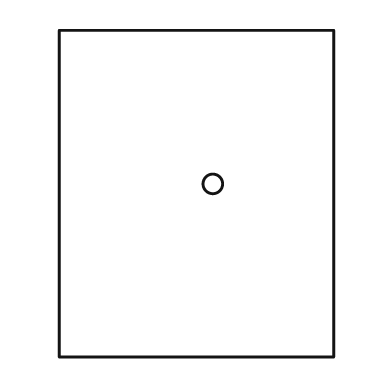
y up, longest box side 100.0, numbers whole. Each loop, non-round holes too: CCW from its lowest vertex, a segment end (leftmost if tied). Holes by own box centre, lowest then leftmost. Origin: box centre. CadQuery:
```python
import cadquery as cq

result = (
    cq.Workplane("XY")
    .moveTo(-42.0, -50.0)
    .lineTo(42.0, -50.0)
    .lineTo(42.0, 50.0)
    .lineTo(-42.0, 50.0)
    .close()
    .moveTo(5.0, 3.0)
    .circle(3.0)
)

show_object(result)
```